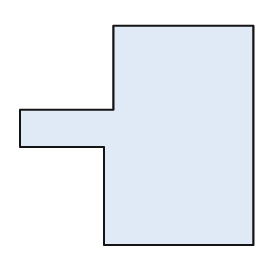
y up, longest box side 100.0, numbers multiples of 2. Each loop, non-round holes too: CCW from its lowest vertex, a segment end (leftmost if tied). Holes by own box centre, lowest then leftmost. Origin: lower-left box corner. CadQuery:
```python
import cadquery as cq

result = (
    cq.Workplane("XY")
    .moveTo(36.0, 0.0)
    .lineTo(100.0, 0.0)
    .lineTo(100.0, 94.0)
    .lineTo(40.0, 94.0)
    .lineTo(40.0, 58.0)
    .lineTo(0.0, 58.0)
    .lineTo(0.0, 42.0)
    .lineTo(36.0, 42.0)
    .close()
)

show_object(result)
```